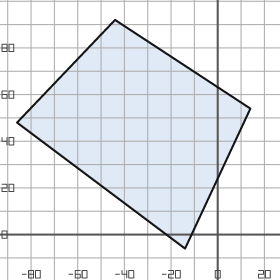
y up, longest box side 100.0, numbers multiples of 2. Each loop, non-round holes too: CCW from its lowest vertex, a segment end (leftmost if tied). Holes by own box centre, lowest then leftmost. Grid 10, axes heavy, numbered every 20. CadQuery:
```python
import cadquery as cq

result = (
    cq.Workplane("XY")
    .moveTo(-14.0, -6.0)
    .lineTo(14.0, 54.0)
    .lineTo(-44.0, 92.0)
    .lineTo(-86.0, 48.0)
    .close()
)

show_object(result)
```